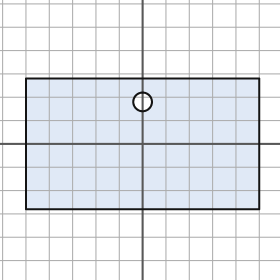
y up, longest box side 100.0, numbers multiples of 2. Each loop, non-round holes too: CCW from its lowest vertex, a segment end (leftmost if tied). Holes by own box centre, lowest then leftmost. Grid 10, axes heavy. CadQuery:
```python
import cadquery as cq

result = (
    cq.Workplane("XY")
    .moveTo(-50.0, -28.0)
    .lineTo(50.0, -28.0)
    .lineTo(50.0, 28.0)
    .lineTo(-50.0, 28.0)
    .close()
    .moveTo(0.0, 18.0)
    .circle(4.0)
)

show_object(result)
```